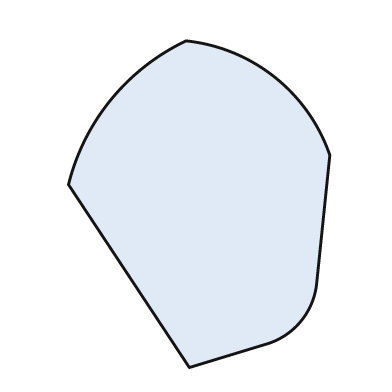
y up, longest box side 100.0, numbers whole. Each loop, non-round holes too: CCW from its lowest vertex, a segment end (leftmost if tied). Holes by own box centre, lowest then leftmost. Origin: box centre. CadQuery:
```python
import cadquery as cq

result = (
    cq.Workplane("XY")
    .moveTo(-3.0, -50.0)
    .lineTo(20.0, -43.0)
    .threePointArc((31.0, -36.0), (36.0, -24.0))
    .lineTo(40.0, 15.0)
    .threePointArc((23.0, 39.0), (-4.0, 50.0))
    .threePointArc((-27.0, 32.0), (-40.0, 6.0))
    .close()
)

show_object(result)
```